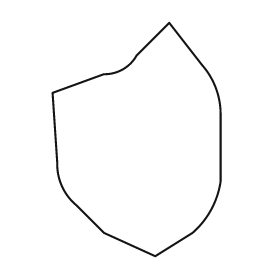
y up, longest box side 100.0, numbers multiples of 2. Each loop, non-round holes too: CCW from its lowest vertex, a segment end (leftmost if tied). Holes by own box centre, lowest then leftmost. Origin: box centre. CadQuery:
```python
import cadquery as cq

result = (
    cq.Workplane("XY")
    .moveTo(8.0, -50.0)
    .lineTo(24.0, -40.0)
    .threePointArc((32.0, -30.0), (36.0, -18.0))
    .lineTo(36.0, 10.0)
    .threePointArc((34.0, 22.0), (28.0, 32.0))
    .lineTo(14.0, 50.0)
    .lineTo(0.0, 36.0)
    .threePointArc((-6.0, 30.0), (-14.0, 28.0))
    .lineTo(-36.0, 20.0)
    .lineTo(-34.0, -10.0)
    .threePointArc((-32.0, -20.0), (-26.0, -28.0))
    .lineTo(-14.0, -40.0)
    .close()
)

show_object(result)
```